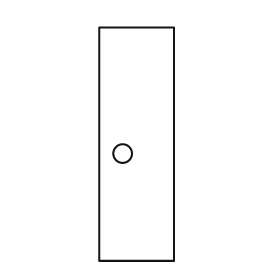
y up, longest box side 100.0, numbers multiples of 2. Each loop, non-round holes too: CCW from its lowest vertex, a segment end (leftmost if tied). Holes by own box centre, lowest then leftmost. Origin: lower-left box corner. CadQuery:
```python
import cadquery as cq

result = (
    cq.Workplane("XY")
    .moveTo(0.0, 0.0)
    .lineTo(32.0, 0.0)
    .lineTo(32.0, 100.0)
    .lineTo(0.0, 100.0)
    .close()
    .moveTo(10.0, 46.0)
    .circle(4.0)
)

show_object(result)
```